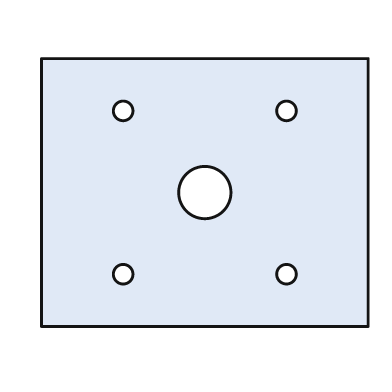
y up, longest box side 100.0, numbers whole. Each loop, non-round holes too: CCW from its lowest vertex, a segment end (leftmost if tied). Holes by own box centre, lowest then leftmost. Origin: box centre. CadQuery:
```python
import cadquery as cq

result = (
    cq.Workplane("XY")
    .moveTo(-50.0, -41.0)
    .lineTo(50.0, -41.0)
    .lineTo(50.0, 41.0)
    .lineTo(-50.0, 41.0)
    .close()
    .moveTo(-25.0, -25.0)
    .circle(3.0)
    .moveTo(25.0, -25.0)
    .circle(3.0)
    .moveTo(0.0, 0.0)
    .circle(8.0)
    .moveTo(-25.0, 25.0)
    .circle(3.0)
    .moveTo(25.0, 25.0)
    .circle(3.0)
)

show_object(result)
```